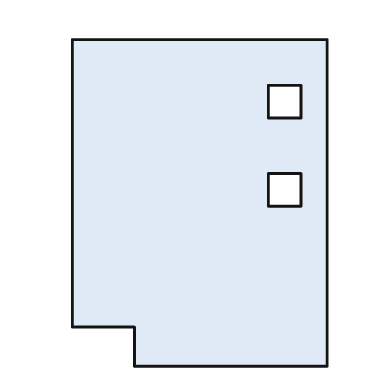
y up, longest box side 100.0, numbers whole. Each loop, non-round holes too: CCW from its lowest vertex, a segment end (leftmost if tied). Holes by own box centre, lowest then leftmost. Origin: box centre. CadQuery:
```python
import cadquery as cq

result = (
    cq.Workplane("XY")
    .moveTo(-20.0, -50.0)
    .lineTo(39.0, -50.0)
    .lineTo(39.0, 50.0)
    .lineTo(-39.0, 50.0)
    .lineTo(-39.0, -38.0)
    .lineTo(-20.0, -38.0)
    .close()
    .moveTo(21.0, -1.0)
    .lineTo(31.0, -1.0)
    .lineTo(31.0, 9.0)
    .lineTo(21.0, 9.0)
    .close()
    .moveTo(21.0, 26.0)
    .lineTo(31.0, 26.0)
    .lineTo(31.0, 36.0)
    .lineTo(21.0, 36.0)
    .close()
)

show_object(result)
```